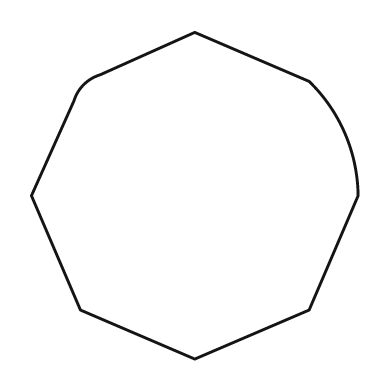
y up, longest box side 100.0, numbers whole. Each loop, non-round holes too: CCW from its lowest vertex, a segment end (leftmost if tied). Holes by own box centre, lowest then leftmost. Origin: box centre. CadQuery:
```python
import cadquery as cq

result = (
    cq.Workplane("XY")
    .moveTo(0.0, -50.0)
    .lineTo(35.0, -35.0)
    .lineTo(50.0, 0.0)
    .threePointArc((46.0, 19.0), (35.0, 35.0))
    .lineTo(0.0, 50.0)
    .lineTo(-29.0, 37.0)
    .threePointArc((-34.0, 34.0), (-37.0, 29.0))
    .lineTo(-50.0, 0.0)
    .lineTo(-35.0, -35.0)
    .close()
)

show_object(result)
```